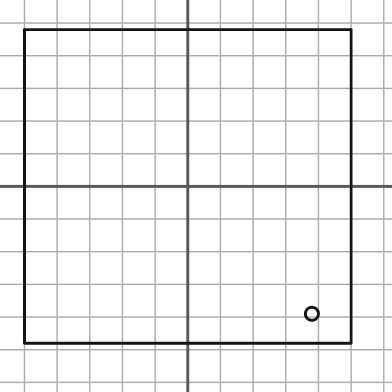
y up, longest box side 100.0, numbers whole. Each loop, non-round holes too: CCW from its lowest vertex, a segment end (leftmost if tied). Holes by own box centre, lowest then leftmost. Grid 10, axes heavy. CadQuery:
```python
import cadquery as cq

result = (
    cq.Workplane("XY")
    .moveTo(-50.0, -48.0)
    .lineTo(50.0, -48.0)
    .lineTo(50.0, 48.0)
    .lineTo(-50.0, 48.0)
    .close()
    .moveTo(38.0, -39.0)
    .circle(2.0)
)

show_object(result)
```